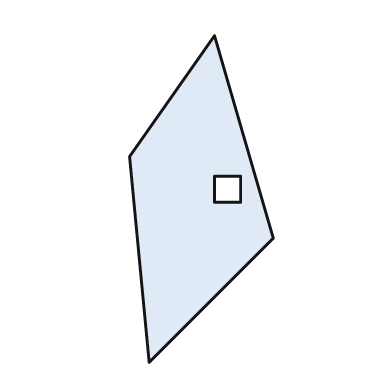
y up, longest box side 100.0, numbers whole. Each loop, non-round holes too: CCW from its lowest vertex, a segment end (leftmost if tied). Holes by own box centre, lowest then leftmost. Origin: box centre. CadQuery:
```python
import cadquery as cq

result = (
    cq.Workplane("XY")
    .moveTo(-16.0, -50.0)
    .lineTo(22.0, -12.0)
    .lineTo(4.0, 50.0)
    .lineTo(-22.0, 13.0)
    .close()
    .moveTo(4.0, -1.0)
    .lineTo(12.0, -1.0)
    .lineTo(12.0, 7.0)
    .lineTo(4.0, 7.0)
    .close()
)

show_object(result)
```